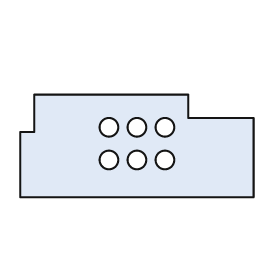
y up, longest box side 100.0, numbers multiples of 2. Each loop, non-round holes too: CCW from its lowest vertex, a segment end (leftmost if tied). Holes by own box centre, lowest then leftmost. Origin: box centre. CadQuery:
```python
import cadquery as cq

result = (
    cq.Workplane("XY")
    .moveTo(-50.0, -22.0)
    .lineTo(50.0, -22.0)
    .lineTo(50.0, 12.0)
    .lineTo(22.0, 12.0)
    .lineTo(22.0, 22.0)
    .lineTo(-44.0, 22.0)
    .lineTo(-44.0, 6.0)
    .lineTo(-50.0, 6.0)
    .close()
    .moveTo(-12.0, -6.0)
    .circle(4.0)
    .moveTo(0.0, -6.0)
    .circle(4.0)
    .moveTo(12.0, -6.0)
    .circle(4.0)
    .moveTo(-12.0, 8.0)
    .circle(4.0)
    .moveTo(0.0, 8.0)
    .circle(4.0)
    .moveTo(12.0, 8.0)
    .circle(4.0)
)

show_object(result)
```